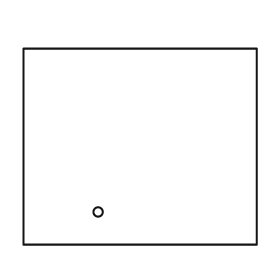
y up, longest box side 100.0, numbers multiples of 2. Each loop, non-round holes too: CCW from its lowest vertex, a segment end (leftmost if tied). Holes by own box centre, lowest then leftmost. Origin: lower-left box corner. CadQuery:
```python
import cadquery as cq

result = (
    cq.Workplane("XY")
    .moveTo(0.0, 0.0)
    .lineTo(100.0, 0.0)
    .lineTo(100.0, 84.0)
    .lineTo(0.0, 84.0)
    .close()
    .moveTo(32.0, 14.0)
    .circle(2.0)
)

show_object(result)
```